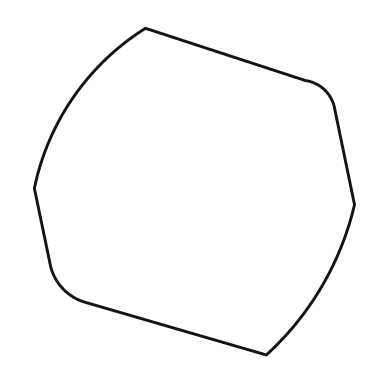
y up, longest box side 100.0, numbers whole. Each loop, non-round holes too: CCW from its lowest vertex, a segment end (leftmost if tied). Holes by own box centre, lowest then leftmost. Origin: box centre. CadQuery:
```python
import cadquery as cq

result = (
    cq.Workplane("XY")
    .moveTo(22.0, -50.0)
    .threePointArc((39.0, -29.0), (49.0, -4.0))
    .lineTo(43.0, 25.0)
    .threePointArc((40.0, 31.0), (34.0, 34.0))
    .lineTo(-15.0, 50.0)
    .threePointArc((-37.0, 29.0), (-49.0, 1.0))
    .lineTo(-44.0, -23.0)
    .threePointArc((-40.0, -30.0), (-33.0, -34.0))
    .close()
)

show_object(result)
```